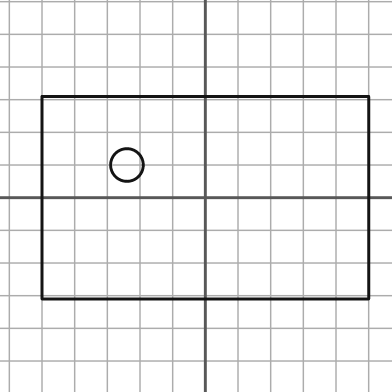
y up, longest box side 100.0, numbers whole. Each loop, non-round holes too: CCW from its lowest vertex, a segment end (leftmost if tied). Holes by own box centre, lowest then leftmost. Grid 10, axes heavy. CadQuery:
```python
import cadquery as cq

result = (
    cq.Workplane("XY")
    .moveTo(-50.0, -31.0)
    .lineTo(50.0, -31.0)
    .lineTo(50.0, 31.0)
    .lineTo(-50.0, 31.0)
    .close()
    .moveTo(-24.0, 10.0)
    .circle(5.0)
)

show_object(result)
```